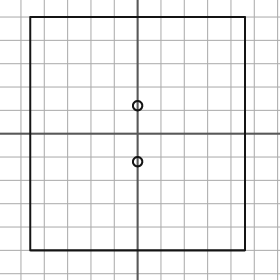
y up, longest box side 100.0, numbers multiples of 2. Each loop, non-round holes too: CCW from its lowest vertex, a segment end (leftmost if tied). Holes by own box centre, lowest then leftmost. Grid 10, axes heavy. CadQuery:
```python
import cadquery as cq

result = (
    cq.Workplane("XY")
    .moveTo(-46.0, -50.0)
    .lineTo(46.0, -50.0)
    .lineTo(46.0, 50.0)
    .lineTo(-46.0, 50.0)
    .close()
    .moveTo(0.0, -12.0)
    .circle(2.0)
    .moveTo(0.0, 12.0)
    .circle(2.0)
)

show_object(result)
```